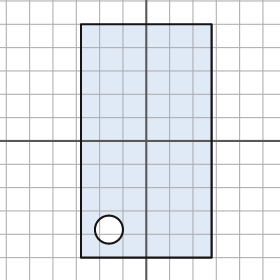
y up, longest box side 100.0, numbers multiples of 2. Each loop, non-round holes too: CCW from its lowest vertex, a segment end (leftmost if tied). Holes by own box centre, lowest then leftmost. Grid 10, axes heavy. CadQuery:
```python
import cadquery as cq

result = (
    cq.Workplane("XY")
    .moveTo(-28.0, -50.0)
    .lineTo(28.0, -50.0)
    .lineTo(28.0, 50.0)
    .lineTo(-28.0, 50.0)
    .close()
    .moveTo(-16.0, -38.0)
    .circle(6.0)
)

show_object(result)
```